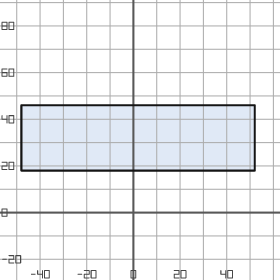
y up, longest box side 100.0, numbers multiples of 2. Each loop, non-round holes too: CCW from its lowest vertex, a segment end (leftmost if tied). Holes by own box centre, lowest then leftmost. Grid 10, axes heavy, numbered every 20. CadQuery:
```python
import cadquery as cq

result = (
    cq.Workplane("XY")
    .moveTo(-48.0, 18.0)
    .lineTo(52.0, 18.0)
    .lineTo(52.0, 46.0)
    .lineTo(-48.0, 46.0)
    .close()
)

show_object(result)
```